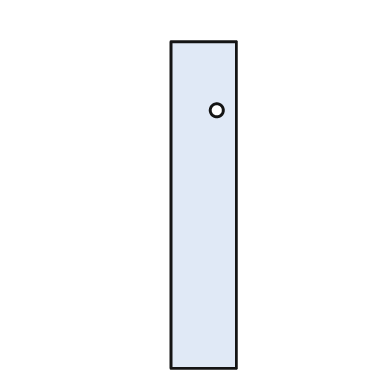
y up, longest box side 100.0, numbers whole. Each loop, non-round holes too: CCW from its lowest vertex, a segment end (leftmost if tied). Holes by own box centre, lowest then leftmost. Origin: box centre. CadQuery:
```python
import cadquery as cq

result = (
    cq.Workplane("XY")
    .moveTo(-10.0, -50.0)
    .lineTo(10.0, -50.0)
    .lineTo(10.0, 50.0)
    .lineTo(-10.0, 50.0)
    .close()
    .moveTo(4.0, 29.0)
    .circle(2.0)
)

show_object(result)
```